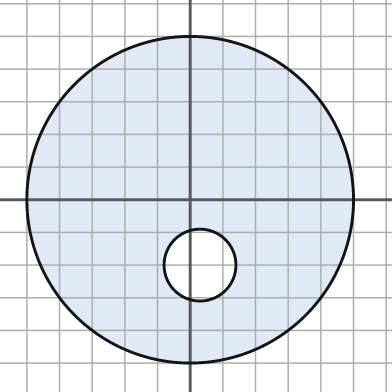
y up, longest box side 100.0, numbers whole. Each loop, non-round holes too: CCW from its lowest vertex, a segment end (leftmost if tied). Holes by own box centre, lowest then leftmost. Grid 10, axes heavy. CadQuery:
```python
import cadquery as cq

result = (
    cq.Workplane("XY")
    .moveTo(0.0, 0.0)
    .circle(50.0)
    .moveTo(3.0, -20.0)
    .circle(11.0)
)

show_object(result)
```